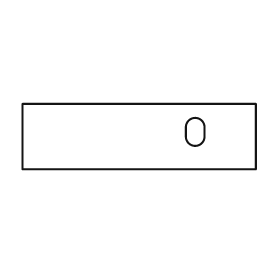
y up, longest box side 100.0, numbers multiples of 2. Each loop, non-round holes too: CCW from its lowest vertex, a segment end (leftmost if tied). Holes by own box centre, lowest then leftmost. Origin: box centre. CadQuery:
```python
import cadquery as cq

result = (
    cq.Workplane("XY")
    .moveTo(-50.0, -14.0)
    .lineTo(50.0, -14.0)
    .lineTo(50.0, 14.0)
    .lineTo(-50.0, 14.0)
    .close()
    .moveTo(20.0, 0.0)
    .threePointArc((24.0, -4.0), (28.0, 0.0))
    .lineTo(28.0, 4.0)
    .threePointArc((24.0, 8.0), (20.0, 4.0))
    .close()
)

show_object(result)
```